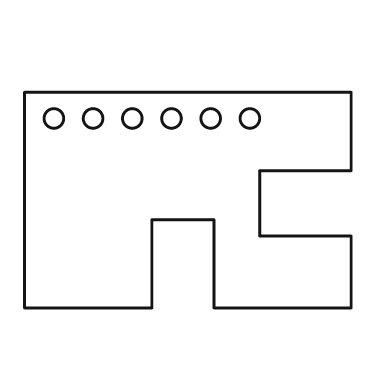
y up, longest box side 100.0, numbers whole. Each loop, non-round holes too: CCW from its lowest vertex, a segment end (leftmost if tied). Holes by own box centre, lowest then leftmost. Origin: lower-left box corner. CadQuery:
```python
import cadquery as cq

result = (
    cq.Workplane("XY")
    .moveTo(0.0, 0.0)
    .lineTo(39.0, 0.0)
    .lineTo(39.0, 27.0)
    .lineTo(58.0, 27.0)
    .lineTo(58.0, 0.0)
    .lineTo(100.0, 0.0)
    .lineTo(100.0, 22.0)
    .lineTo(72.0, 22.0)
    .lineTo(72.0, 42.0)
    .lineTo(100.0, 42.0)
    .lineTo(100.0, 66.0)
    .lineTo(0.0, 66.0)
    .close()
    .moveTo(9.0, 58.0)
    .circle(3.0)
    .moveTo(21.0, 58.0)
    .circle(3.0)
    .moveTo(33.0, 58.0)
    .circle(3.0)
    .moveTo(45.0, 58.0)
    .circle(3.0)
    .moveTo(57.0, 58.0)
    .circle(3.0)
    .moveTo(69.0, 58.0)
    .circle(3.0)
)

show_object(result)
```